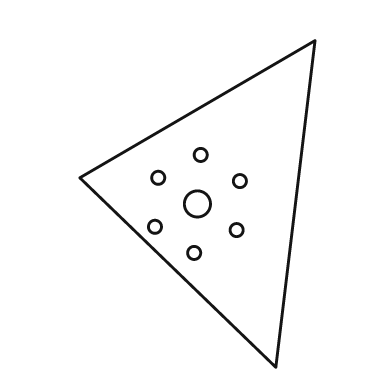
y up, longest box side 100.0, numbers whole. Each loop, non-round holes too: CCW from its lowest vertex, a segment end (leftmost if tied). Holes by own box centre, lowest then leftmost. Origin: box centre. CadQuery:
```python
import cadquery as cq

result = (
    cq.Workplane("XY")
    .moveTo(24.0, -50.0)
    .lineTo(36.0, 50.0)
    .lineTo(-36.0, 8.0)
    .close()
    .moveTo(-1.0, -15.0)
    .circle(2.0)
    .moveTo(12.0, -8.0)
    .circle(2.0)
    .moveTo(-13.0, -7.0)
    .circle(2.0)
    .moveTo(0.0, 0.0)
    .circle(4.0)
    .moveTo(13.0, 7.0)
    .circle(2.0)
    .moveTo(-12.0, 8.0)
    .circle(2.0)
    .moveTo(1.0, 15.0)
    .circle(2.0)
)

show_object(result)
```